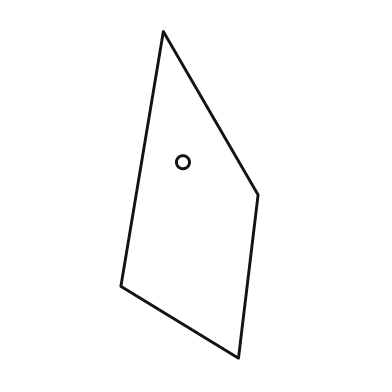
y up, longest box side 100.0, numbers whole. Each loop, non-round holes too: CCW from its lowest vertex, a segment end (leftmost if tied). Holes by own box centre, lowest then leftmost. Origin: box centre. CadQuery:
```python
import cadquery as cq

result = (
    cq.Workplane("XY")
    .moveTo(15.0, -50.0)
    .lineTo(21.0, 0.0)
    .lineTo(-8.0, 50.0)
    .lineTo(-21.0, -28.0)
    .close()
    .moveTo(-2.0, 10.0)
    .circle(2.0)
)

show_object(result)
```